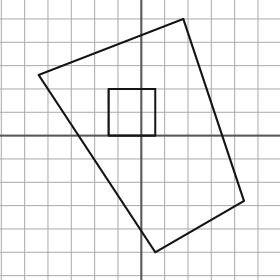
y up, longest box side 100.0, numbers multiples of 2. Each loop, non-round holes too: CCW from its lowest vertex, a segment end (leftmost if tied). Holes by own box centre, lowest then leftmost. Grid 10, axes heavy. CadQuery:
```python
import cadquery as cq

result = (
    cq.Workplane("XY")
    .moveTo(6.0, -50.0)
    .lineTo(44.0, -28.0)
    .lineTo(18.0, 50.0)
    .lineTo(-44.0, 26.0)
    .close()
    .moveTo(-14.0, 0.0)
    .lineTo(6.0, 0.0)
    .lineTo(6.0, 20.0)
    .lineTo(-14.0, 20.0)
    .close()
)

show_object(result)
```